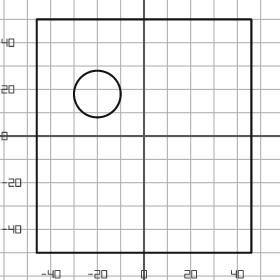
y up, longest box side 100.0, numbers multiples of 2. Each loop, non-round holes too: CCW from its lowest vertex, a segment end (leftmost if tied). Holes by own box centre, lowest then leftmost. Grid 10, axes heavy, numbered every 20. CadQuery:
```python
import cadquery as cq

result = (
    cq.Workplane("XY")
    .moveTo(-46.0, -50.0)
    .lineTo(46.0, -50.0)
    .lineTo(46.0, 50.0)
    .lineTo(-46.0, 50.0)
    .close()
    .moveTo(-20.0, 18.0)
    .circle(10.0)
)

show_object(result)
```